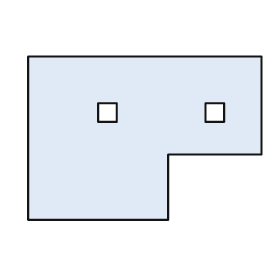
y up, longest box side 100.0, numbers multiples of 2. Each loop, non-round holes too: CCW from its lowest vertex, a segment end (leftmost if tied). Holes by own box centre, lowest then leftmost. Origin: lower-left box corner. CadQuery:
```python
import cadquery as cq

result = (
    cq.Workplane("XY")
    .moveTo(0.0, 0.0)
    .lineTo(60.0, 0.0)
    .lineTo(60.0, 28.0)
    .lineTo(100.0, 28.0)
    .lineTo(100.0, 70.0)
    .lineTo(0.0, 70.0)
    .close()
    .moveTo(30.0, 42.0)
    .lineTo(38.0, 42.0)
    .lineTo(38.0, 50.0)
    .lineTo(30.0, 50.0)
    .close()
    .moveTo(76.0, 42.0)
    .lineTo(84.0, 42.0)
    .lineTo(84.0, 50.0)
    .lineTo(76.0, 50.0)
    .close()
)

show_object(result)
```